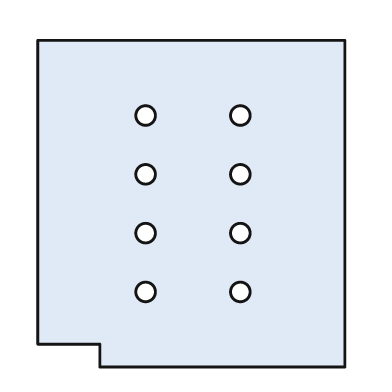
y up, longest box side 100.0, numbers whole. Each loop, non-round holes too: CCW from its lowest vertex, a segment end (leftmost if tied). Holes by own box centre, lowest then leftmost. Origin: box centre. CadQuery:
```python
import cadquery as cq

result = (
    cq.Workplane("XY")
    .moveTo(-28.0, -50.0)
    .lineTo(47.0, -50.0)
    .lineTo(47.0, 50.0)
    .lineTo(-47.0, 50.0)
    .lineTo(-47.0, -43.0)
    .lineTo(-28.0, -43.0)
    .close()
    .moveTo(-14.0, -27.0)
    .circle(3.0)
    .moveTo(15.0, -27.0)
    .circle(3.0)
    .moveTo(-14.0, -9.0)
    .circle(3.0)
    .moveTo(15.0, -9.0)
    .circle(3.0)
    .moveTo(-14.0, 9.0)
    .circle(3.0)
    .moveTo(15.0, 9.0)
    .circle(3.0)
    .moveTo(-14.0, 27.0)
    .circle(3.0)
    .moveTo(15.0, 27.0)
    .circle(3.0)
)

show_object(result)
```